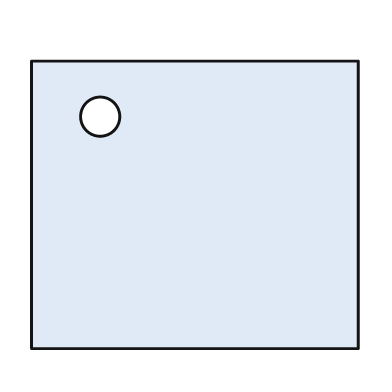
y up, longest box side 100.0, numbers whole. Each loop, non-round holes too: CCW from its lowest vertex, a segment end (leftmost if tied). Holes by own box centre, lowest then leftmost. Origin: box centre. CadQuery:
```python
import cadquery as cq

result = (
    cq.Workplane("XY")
    .moveTo(-50.0, -44.0)
    .lineTo(50.0, -44.0)
    .lineTo(50.0, 44.0)
    .lineTo(-50.0, 44.0)
    .close()
    .moveTo(-29.0, 27.0)
    .circle(6.0)
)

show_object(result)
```